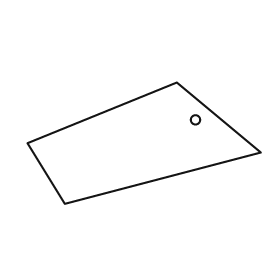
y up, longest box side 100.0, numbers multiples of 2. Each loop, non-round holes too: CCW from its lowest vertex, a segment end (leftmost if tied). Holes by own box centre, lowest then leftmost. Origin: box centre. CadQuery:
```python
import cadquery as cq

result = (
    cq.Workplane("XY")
    .moveTo(-34.0, -26.0)
    .lineTo(50.0, -4.0)
    .lineTo(14.0, 26.0)
    .lineTo(-50.0, 0.0)
    .close()
    .moveTo(22.0, 10.0)
    .circle(2.0)
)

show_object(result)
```